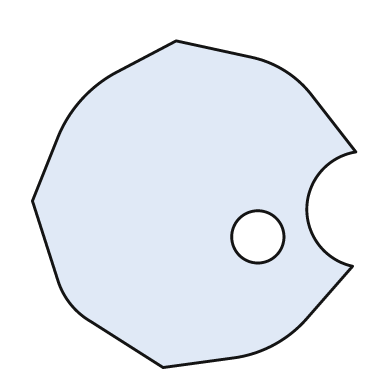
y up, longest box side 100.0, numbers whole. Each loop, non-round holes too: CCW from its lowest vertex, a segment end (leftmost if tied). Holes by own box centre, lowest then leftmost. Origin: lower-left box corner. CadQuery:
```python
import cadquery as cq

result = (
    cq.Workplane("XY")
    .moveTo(40.0, 0.0)
    .lineTo(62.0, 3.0)
    .threePointArc((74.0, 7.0), (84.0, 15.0))
    .lineTo(98.0, 31.0)
    .threePointArc((84.0, 49.0), (99.0, 66.0))
    .lineTo(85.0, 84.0)
    .threePointArc((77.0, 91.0), (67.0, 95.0))
    .lineTo(44.0, 100.0)
    .lineTo(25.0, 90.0)
    .threePointArc((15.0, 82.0), (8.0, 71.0))
    .lineTo(0.0, 51.0)
    .lineTo(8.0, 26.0)
    .threePointArc((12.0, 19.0), (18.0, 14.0))
    .close()
    .moveTo(69.0, 40.0)
    .circle(8.0)
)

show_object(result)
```